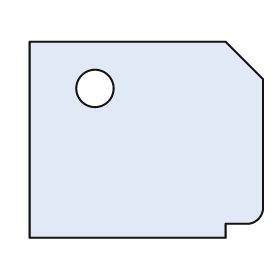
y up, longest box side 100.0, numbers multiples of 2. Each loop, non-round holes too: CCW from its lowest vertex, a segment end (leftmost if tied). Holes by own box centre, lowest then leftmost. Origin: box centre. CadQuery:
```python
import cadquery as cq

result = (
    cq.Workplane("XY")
    .moveTo(-50.0, -42.0)
    .lineTo(34.0, -42.0)
    .lineTo(34.0, -36.0)
    .lineTo(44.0, -36.0)
    .threePointArc((48.0, -34.0), (50.0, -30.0))
    .lineTo(50.0, 26.0)
    .lineTo(34.0, 42.0)
    .lineTo(-50.0, 42.0)
    .close()
    .moveTo(-22.0, 22.0)
    .circle(8.0)
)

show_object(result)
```